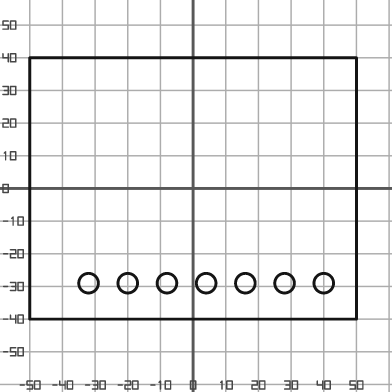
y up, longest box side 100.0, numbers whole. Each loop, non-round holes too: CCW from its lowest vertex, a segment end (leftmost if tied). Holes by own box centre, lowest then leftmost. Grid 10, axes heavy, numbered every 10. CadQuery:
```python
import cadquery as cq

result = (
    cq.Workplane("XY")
    .moveTo(-50.0, -40.0)
    .lineTo(50.0, -40.0)
    .lineTo(50.0, 40.0)
    .lineTo(-50.0, 40.0)
    .close()
    .moveTo(-32.0, -29.0)
    .circle(3.0)
    .moveTo(-20.0, -29.0)
    .circle(3.0)
    .moveTo(-8.0, -29.0)
    .circle(3.0)
    .moveTo(4.0, -29.0)
    .circle(3.0)
    .moveTo(16.0, -29.0)
    .circle(3.0)
    .moveTo(28.0, -29.0)
    .circle(3.0)
    .moveTo(40.0, -29.0)
    .circle(3.0)
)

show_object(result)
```